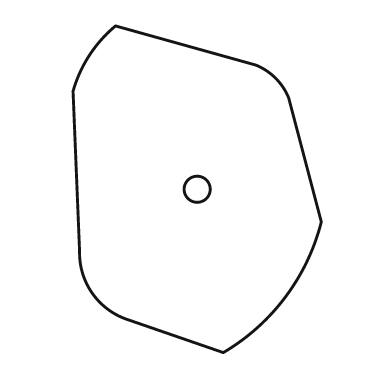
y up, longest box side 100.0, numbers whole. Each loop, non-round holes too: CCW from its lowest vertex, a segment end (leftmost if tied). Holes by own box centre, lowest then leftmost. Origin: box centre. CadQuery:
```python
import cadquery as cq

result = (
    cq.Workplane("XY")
    .moveTo(8.0, -50.0)
    .threePointArc((27.0, -33.0), (38.0, -10.0))
    .lineTo(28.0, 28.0)
    .threePointArc((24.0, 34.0), (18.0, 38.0))
    .lineTo(-25.0, 50.0)
    .threePointArc((-33.0, 41.0), (-38.0, 30.0))
    .lineTo(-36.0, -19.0)
    .threePointArc((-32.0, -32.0), (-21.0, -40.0))
    .close()
    .moveTo(0.0, 0.0)
    .circle(4.0)
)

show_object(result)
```